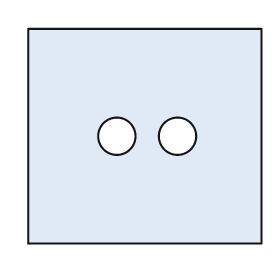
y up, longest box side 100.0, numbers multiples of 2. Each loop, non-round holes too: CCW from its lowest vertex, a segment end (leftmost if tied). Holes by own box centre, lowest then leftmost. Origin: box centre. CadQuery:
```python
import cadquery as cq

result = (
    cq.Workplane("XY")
    .moveTo(-50.0, -46.0)
    .lineTo(50.0, -46.0)
    .lineTo(50.0, 46.0)
    .lineTo(-50.0, 46.0)
    .close()
    .moveTo(-12.0, 0.0)
    .circle(8.0)
    .moveTo(14.0, 0.0)
    .circle(8.0)
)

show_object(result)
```